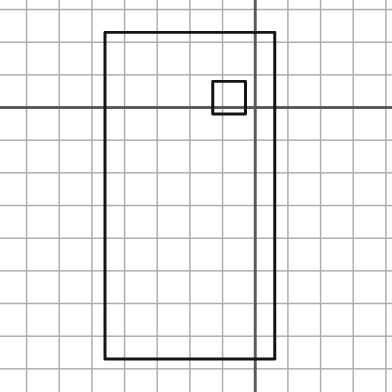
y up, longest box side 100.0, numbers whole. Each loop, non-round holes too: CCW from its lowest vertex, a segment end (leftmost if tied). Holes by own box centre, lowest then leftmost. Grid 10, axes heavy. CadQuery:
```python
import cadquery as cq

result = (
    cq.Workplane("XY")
    .moveTo(-46.0, -77.0)
    .lineTo(6.0, -77.0)
    .lineTo(6.0, 23.0)
    .lineTo(-46.0, 23.0)
    .close()
    .moveTo(-13.0, -2.0)
    .lineTo(-3.0, -2.0)
    .lineTo(-3.0, 8.0)
    .lineTo(-13.0, 8.0)
    .close()
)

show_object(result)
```